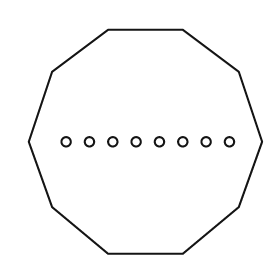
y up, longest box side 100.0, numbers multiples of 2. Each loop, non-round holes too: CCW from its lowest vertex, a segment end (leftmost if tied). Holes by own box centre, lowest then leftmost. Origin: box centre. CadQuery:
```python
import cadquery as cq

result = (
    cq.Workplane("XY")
    .moveTo(-16.0, -48.0)
    .lineTo(16.0, -48.0)
    .lineTo(40.0, -28.0)
    .lineTo(50.0, 0.0)
    .lineTo(40.0, 30.0)
    .lineTo(16.0, 48.0)
    .lineTo(-16.0, 48.0)
    .lineTo(-40.0, 30.0)
    .lineTo(-50.0, 0.0)
    .lineTo(-40.0, -28.0)
    .close()
    .moveTo(-34.0, 0.0)
    .circle(2.0)
    .moveTo(-24.0, 0.0)
    .circle(2.0)
    .moveTo(-14.0, 0.0)
    .circle(2.0)
    .moveTo(-4.0, 0.0)
    .circle(2.0)
    .moveTo(6.0, 0.0)
    .circle(2.0)
    .moveTo(16.0, 0.0)
    .circle(2.0)
    .moveTo(26.0, 0.0)
    .circle(2.0)
    .moveTo(36.0, 0.0)
    .circle(2.0)
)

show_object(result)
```